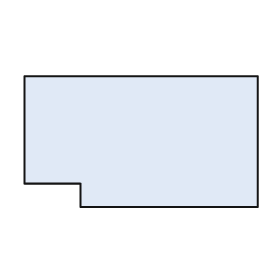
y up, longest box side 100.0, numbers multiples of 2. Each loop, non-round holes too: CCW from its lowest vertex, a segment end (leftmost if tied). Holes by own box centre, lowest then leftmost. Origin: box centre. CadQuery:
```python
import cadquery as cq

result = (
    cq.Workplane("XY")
    .moveTo(-26.0, -28.0)
    .lineTo(50.0, -28.0)
    .lineTo(50.0, 28.0)
    .lineTo(-50.0, 28.0)
    .lineTo(-50.0, -18.0)
    .lineTo(-26.0, -18.0)
    .close()
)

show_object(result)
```